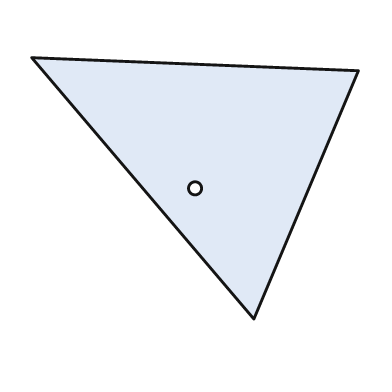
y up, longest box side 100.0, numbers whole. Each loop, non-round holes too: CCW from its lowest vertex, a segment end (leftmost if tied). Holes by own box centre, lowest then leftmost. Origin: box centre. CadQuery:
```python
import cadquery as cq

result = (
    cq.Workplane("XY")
    .moveTo(18.0, -40.0)
    .lineTo(50.0, 36.0)
    .lineTo(-50.0, 40.0)
    .close()
    .moveTo(0.0, 0.0)
    .circle(2.0)
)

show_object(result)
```